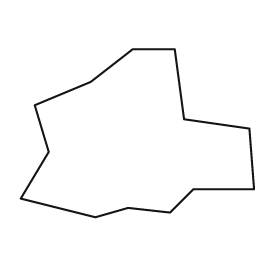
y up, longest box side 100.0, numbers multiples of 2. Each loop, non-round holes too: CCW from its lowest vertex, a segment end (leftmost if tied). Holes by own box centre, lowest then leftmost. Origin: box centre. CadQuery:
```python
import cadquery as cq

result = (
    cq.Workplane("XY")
    .moveTo(-18.0, -36.0)
    .lineTo(-4.0, -32.0)
    .lineTo(14.0, -34.0)
    .lineTo(24.0, -24.0)
    .lineTo(50.0, -24.0)
    .lineTo(48.0, 2.0)
    .lineTo(20.0, 6.0)
    .lineTo(16.0, 36.0)
    .lineTo(-2.0, 36.0)
    .lineTo(-20.0, 22.0)
    .lineTo(-44.0, 12.0)
    .lineTo(-38.0, -8.0)
    .lineTo(-50.0, -28.0)
    .close()
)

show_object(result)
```